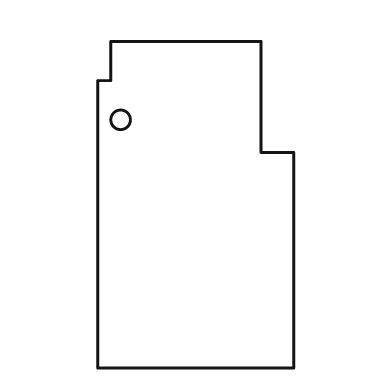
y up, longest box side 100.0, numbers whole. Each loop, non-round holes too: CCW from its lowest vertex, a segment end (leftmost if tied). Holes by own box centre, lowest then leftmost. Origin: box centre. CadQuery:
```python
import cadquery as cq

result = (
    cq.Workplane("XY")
    .moveTo(-30.0, -50.0)
    .lineTo(30.0, -50.0)
    .lineTo(30.0, 16.0)
    .lineTo(20.0, 16.0)
    .lineTo(20.0, 50.0)
    .lineTo(-26.0, 50.0)
    .lineTo(-26.0, 38.0)
    .lineTo(-30.0, 38.0)
    .close()
    .moveTo(-23.0, 26.0)
    .circle(3.0)
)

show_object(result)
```